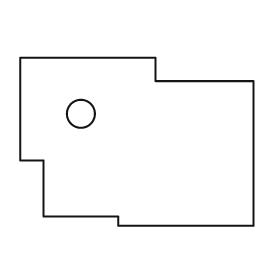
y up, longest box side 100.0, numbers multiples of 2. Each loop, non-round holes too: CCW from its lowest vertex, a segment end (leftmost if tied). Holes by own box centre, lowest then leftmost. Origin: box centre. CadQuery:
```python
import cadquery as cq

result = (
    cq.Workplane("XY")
    .moveTo(-8.0, -36.0)
    .lineTo(50.0, -36.0)
    .lineTo(50.0, 26.0)
    .lineTo(8.0, 26.0)
    .lineTo(8.0, 36.0)
    .lineTo(-50.0, 36.0)
    .lineTo(-50.0, -8.0)
    .lineTo(-40.0, -8.0)
    .lineTo(-40.0, -32.0)
    .lineTo(-8.0, -32.0)
    .close()
    .moveTo(-24.0, 12.0)
    .circle(6.0)
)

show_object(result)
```